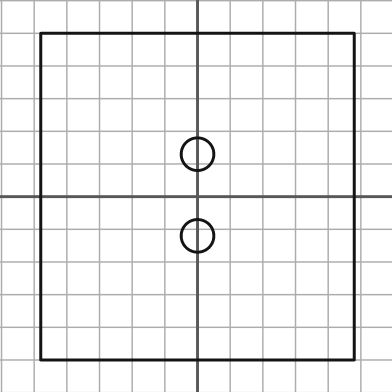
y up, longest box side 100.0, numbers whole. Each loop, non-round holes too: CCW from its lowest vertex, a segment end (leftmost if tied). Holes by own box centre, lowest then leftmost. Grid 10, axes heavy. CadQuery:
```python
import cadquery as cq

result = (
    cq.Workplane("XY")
    .moveTo(-48.0, -50.0)
    .lineTo(48.0, -50.0)
    .lineTo(48.0, 50.0)
    .lineTo(-48.0, 50.0)
    .close()
    .moveTo(0.0, -12.0)
    .circle(5.0)
    .moveTo(0.0, 13.0)
    .circle(5.0)
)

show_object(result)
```